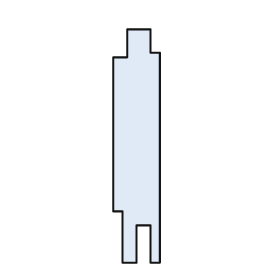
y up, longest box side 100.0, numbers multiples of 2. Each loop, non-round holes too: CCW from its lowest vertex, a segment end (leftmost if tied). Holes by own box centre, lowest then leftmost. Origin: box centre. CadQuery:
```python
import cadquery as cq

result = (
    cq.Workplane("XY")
    .moveTo(-6.0, -50.0)
    .lineTo(0.0, -50.0)
    .lineTo(0.0, -34.0)
    .lineTo(6.0, -34.0)
    .lineTo(6.0, -50.0)
    .lineTo(10.0, -50.0)
    .lineTo(10.0, 40.0)
    .lineTo(6.0, 40.0)
    .lineTo(6.0, 50.0)
    .lineTo(-4.0, 50.0)
    .lineTo(-4.0, 38.0)
    .lineTo(-10.0, 38.0)
    .lineTo(-10.0, -28.0)
    .lineTo(-6.0, -28.0)
    .close()
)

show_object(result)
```